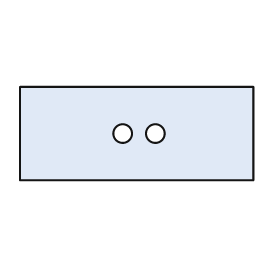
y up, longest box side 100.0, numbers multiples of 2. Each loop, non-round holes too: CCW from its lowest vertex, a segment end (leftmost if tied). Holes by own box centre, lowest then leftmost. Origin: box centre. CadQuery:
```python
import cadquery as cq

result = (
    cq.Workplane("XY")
    .moveTo(-50.0, -20.0)
    .lineTo(50.0, -20.0)
    .lineTo(50.0, 20.0)
    .lineTo(-50.0, 20.0)
    .close()
    .moveTo(-6.0, 0.0)
    .circle(4.0)
    .moveTo(8.0, 0.0)
    .circle(4.0)
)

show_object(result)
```